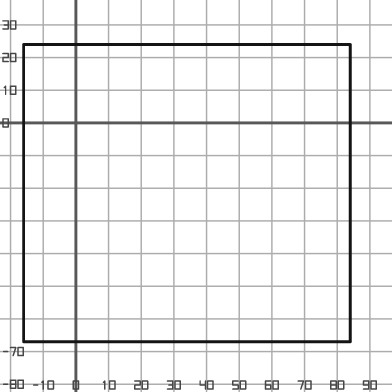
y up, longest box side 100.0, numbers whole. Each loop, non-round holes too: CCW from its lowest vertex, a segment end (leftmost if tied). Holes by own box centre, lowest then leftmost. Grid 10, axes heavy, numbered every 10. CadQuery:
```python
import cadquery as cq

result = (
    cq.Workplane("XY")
    .moveTo(-16.0, -67.0)
    .lineTo(84.0, -67.0)
    .lineTo(84.0, 24.0)
    .lineTo(-16.0, 24.0)
    .close()
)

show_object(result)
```